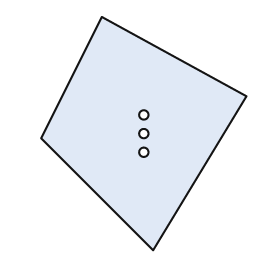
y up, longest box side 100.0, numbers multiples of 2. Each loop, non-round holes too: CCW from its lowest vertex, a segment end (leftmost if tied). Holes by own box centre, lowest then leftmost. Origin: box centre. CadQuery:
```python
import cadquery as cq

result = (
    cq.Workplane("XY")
    .moveTo(4.0, -50.0)
    .lineTo(44.0, 16.0)
    .lineTo(-18.0, 50.0)
    .lineTo(-44.0, -2.0)
    .close()
    .moveTo(0.0, -8.0)
    .circle(2.0)
    .moveTo(0.0, 0.0)
    .circle(2.0)
    .moveTo(0.0, 8.0)
    .circle(2.0)
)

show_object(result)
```